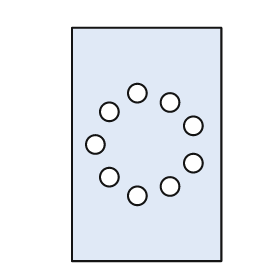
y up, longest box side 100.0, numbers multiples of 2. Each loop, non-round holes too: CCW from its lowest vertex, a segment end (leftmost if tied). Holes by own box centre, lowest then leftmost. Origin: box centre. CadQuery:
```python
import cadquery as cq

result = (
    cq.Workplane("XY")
    .moveTo(-32.0, -50.0)
    .lineTo(32.0, -50.0)
    .lineTo(32.0, 50.0)
    .lineTo(-32.0, 50.0)
    .close()
    .moveTo(-4.0, -22.0)
    .circle(4.0)
    .moveTo(10.0, -18.0)
    .circle(4.0)
    .moveTo(-16.0, -14.0)
    .circle(4.0)
    .moveTo(20.0, -8.0)
    .circle(4.0)
    .moveTo(-22.0, 0.0)
    .circle(4.0)
    .moveTo(20.0, 8.0)
    .circle(4.0)
    .moveTo(-16.0, 14.0)
    .circle(4.0)
    .moveTo(10.0, 18.0)
    .circle(4.0)
    .moveTo(-4.0, 22.0)
    .circle(4.0)
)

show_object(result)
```